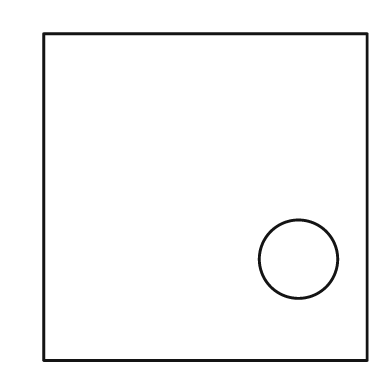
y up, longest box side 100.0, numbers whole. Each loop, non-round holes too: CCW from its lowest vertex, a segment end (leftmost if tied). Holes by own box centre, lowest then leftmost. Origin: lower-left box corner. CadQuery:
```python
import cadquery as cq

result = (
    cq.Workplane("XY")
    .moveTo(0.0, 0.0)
    .lineTo(99.0, 0.0)
    .lineTo(99.0, 100.0)
    .lineTo(0.0, 100.0)
    .close()
    .moveTo(78.0, 31.0)
    .circle(12.0)
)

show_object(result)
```